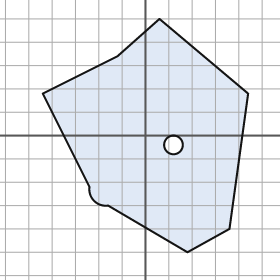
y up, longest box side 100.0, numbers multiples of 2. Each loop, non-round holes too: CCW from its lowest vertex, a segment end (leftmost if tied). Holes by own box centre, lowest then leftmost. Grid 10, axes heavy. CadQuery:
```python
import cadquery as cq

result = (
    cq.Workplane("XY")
    .moveTo(18.0, -50.0)
    .lineTo(36.0, -40.0)
    .lineTo(44.0, 18.0)
    .lineTo(6.0, 50.0)
    .lineTo(-12.0, 34.0)
    .lineTo(-44.0, 18.0)
    .lineTo(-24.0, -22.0)
    .threePointArc((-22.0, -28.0), (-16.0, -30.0))
    .close()
    .moveTo(12.0, -4.0)
    .circle(4.0)
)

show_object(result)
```